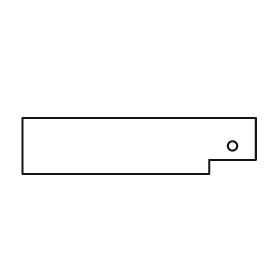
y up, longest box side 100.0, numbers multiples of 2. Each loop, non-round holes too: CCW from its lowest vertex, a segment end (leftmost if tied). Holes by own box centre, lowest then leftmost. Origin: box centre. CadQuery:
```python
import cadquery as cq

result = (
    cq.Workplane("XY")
    .moveTo(-50.0, -12.0)
    .lineTo(30.0, -12.0)
    .lineTo(30.0, -6.0)
    .lineTo(50.0, -6.0)
    .lineTo(50.0, 12.0)
    .lineTo(-50.0, 12.0)
    .close()
    .moveTo(40.0, 0.0)
    .circle(2.0)
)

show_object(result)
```